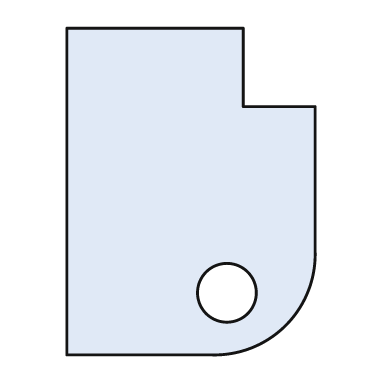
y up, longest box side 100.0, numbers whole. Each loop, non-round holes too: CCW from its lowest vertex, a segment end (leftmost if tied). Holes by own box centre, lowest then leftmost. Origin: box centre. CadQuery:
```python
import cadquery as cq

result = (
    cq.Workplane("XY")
    .moveTo(-38.0, -50.0)
    .lineTo(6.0, -50.0)
    .threePointArc((29.0, -41.0), (38.0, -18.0))
    .lineTo(38.0, 26.0)
    .lineTo(16.0, 26.0)
    .lineTo(16.0, 50.0)
    .lineTo(-38.0, 50.0)
    .close()
    .moveTo(11.0, -31.0)
    .circle(9.0)
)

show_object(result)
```